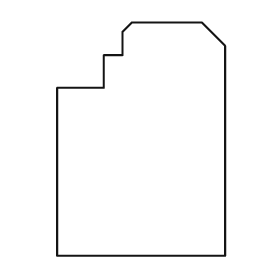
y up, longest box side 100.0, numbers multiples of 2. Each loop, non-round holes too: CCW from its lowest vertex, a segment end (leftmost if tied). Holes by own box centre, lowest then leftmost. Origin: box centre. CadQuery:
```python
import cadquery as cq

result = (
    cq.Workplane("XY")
    .moveTo(-36.0, -50.0)
    .lineTo(36.0, -50.0)
    .lineTo(36.0, 40.0)
    .lineTo(26.0, 50.0)
    .lineTo(-4.0, 50.0)
    .lineTo(-8.0, 46.0)
    .lineTo(-8.0, 36.0)
    .lineTo(-16.0, 36.0)
    .lineTo(-16.0, 22.0)
    .lineTo(-36.0, 22.0)
    .close()
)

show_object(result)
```